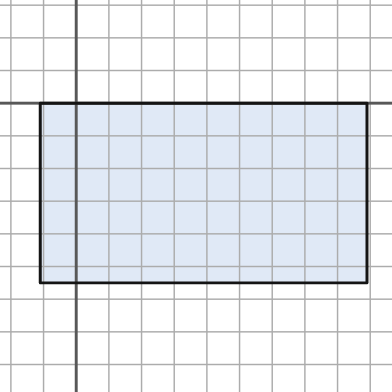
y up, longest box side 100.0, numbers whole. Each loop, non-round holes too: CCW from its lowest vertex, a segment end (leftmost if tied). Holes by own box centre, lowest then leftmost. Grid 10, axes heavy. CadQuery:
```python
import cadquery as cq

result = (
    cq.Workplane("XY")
    .moveTo(-11.0, -55.0)
    .lineTo(89.0, -55.0)
    .lineTo(89.0, 0.0)
    .lineTo(-11.0, 0.0)
    .close()
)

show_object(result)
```